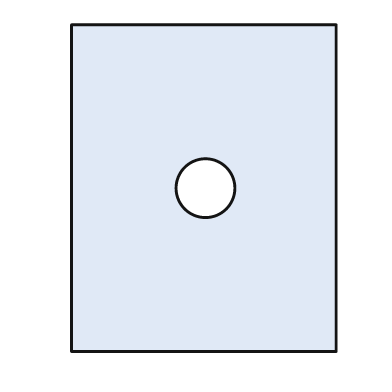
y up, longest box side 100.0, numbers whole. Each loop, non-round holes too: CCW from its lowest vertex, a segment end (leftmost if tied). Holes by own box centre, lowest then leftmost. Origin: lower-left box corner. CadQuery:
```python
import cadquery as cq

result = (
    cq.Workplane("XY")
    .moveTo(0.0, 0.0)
    .lineTo(81.0, 0.0)
    .lineTo(81.0, 100.0)
    .lineTo(0.0, 100.0)
    .close()
    .moveTo(41.0, 50.0)
    .circle(9.0)
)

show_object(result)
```